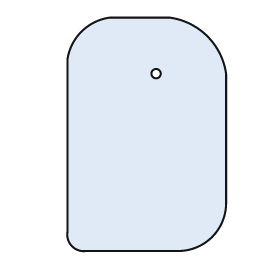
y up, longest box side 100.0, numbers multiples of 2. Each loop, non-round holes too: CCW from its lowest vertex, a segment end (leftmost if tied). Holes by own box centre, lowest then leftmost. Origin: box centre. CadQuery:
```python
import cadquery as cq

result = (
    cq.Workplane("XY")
    .moveTo(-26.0, -50.0)
    .lineTo(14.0, -50.0)
    .threePointArc((28.0, -44.0), (34.0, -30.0))
    .lineTo(34.0, 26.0)
    .threePointArc((26.0, 42.0), (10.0, 50.0))
    .lineTo(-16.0, 50.0)
    .threePointArc((-28.0, 44.0), (-34.0, 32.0))
    .lineTo(-34.0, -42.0)
    .threePointArc((-32.0, -48.0), (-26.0, -50.0))
    .close()
    .moveTo(4.0, 26.0)
    .circle(2.0)
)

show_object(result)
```